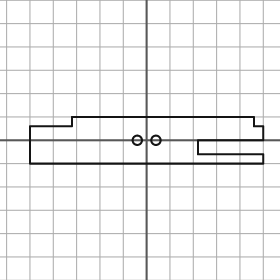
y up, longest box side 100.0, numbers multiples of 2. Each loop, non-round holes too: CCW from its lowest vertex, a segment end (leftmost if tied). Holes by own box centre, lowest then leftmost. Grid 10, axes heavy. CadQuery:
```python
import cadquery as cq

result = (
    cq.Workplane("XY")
    .moveTo(-50.0, -10.0)
    .lineTo(50.0, -10.0)
    .lineTo(50.0, -6.0)
    .lineTo(22.0, -6.0)
    .lineTo(22.0, 0.0)
    .lineTo(50.0, 0.0)
    .lineTo(50.0, 6.0)
    .lineTo(46.0, 6.0)
    .lineTo(46.0, 10.0)
    .lineTo(-32.0, 10.0)
    .lineTo(-32.0, 6.0)
    .lineTo(-50.0, 6.0)
    .close()
    .moveTo(-4.0, 0.0)
    .circle(2.0)
    .moveTo(4.0, 0.0)
    .circle(2.0)
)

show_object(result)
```